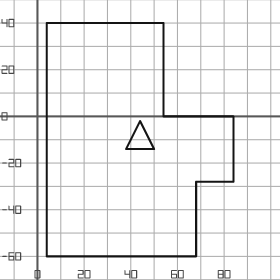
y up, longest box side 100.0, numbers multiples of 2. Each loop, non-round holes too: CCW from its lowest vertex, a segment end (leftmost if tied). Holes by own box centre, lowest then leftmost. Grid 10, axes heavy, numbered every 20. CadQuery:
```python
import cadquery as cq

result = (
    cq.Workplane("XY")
    .moveTo(4.0, -60.0)
    .lineTo(68.0, -60.0)
    .lineTo(68.0, -28.0)
    .lineTo(84.0, -28.0)
    .lineTo(84.0, 0.0)
    .lineTo(54.0, 0.0)
    .lineTo(54.0, 40.0)
    .lineTo(4.0, 40.0)
    .close()
    .moveTo(38.0, -14.0)
    .lineTo(50.0, -14.0)
    .lineTo(44.0, -2.0)
    .close()
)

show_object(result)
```